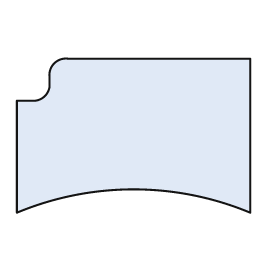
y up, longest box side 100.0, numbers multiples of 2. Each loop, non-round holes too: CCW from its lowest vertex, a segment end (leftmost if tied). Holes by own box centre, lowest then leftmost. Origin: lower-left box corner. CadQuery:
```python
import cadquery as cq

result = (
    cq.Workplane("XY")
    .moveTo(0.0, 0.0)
    .threePointArc((50.0, 10.0), (100.0, 0.0))
    .lineTo(100.0, 66.0)
    .lineTo(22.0, 66.0)
    .threePointArc((16.0, 64.0), (14.0, 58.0))
    .lineTo(14.0, 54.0)
    .threePointArc((12.0, 50.0), (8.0, 48.0))
    .lineTo(0.0, 48.0)
    .close()
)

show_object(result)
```